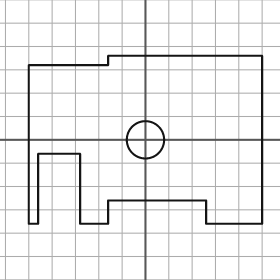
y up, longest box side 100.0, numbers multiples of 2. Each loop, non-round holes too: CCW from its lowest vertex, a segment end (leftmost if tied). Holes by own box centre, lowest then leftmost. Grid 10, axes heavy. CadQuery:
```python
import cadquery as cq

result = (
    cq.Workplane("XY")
    .moveTo(-50.0, -36.0)
    .lineTo(-46.0, -36.0)
    .lineTo(-46.0, -6.0)
    .lineTo(-28.0, -6.0)
    .lineTo(-28.0, -36.0)
    .lineTo(-16.0, -36.0)
    .lineTo(-16.0, -26.0)
    .lineTo(26.0, -26.0)
    .lineTo(26.0, -36.0)
    .lineTo(50.0, -36.0)
    .lineTo(50.0, 36.0)
    .lineTo(-16.0, 36.0)
    .lineTo(-16.0, 32.0)
    .lineTo(-50.0, 32.0)
    .close()
    .moveTo(0.0, 0.0)
    .circle(8.0)
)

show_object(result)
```